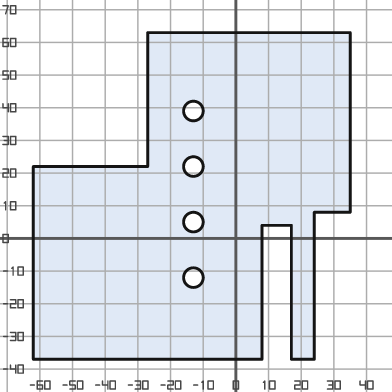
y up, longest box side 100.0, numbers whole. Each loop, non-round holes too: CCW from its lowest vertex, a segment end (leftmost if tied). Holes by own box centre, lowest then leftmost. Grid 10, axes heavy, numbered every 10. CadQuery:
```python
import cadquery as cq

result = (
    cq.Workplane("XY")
    .moveTo(-62.0, -37.0)
    .lineTo(8.0, -37.0)
    .lineTo(8.0, 4.0)
    .lineTo(17.0, 4.0)
    .lineTo(17.0, -37.0)
    .lineTo(24.0, -37.0)
    .lineTo(24.0, 8.0)
    .lineTo(35.0, 8.0)
    .lineTo(35.0, 63.0)
    .lineTo(-27.0, 63.0)
    .lineTo(-27.0, 22.0)
    .lineTo(-62.0, 22.0)
    .close()
    .moveTo(-13.0, -12.0)
    .circle(3.0)
    .moveTo(-13.0, 5.0)
    .circle(3.0)
    .moveTo(-13.0, 22.0)
    .circle(3.0)
    .moveTo(-13.0, 39.0)
    .circle(3.0)
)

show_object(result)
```